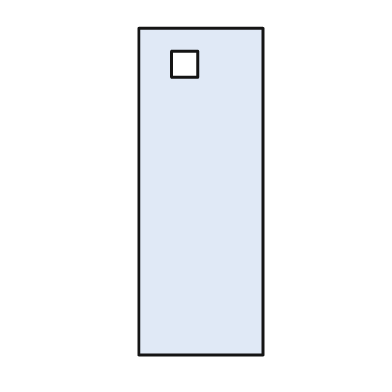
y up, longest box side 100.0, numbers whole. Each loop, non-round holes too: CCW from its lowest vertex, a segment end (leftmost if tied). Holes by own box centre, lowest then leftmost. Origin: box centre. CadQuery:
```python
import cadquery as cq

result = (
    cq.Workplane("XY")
    .moveTo(-19.0, -50.0)
    .lineTo(19.0, -50.0)
    .lineTo(19.0, 50.0)
    .lineTo(-19.0, 50.0)
    .close()
    .moveTo(-9.0, 35.0)
    .lineTo(-1.0, 35.0)
    .lineTo(-1.0, 43.0)
    .lineTo(-9.0, 43.0)
    .close()
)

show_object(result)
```